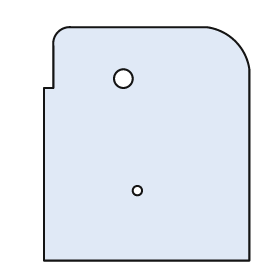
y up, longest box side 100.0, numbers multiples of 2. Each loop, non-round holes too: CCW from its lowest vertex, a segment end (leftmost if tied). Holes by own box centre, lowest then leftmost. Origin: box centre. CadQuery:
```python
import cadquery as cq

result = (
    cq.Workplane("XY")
    .moveTo(-44.0, -50.0)
    .lineTo(44.0, -50.0)
    .lineTo(44.0, 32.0)
    .threePointArc((38.0, 44.0), (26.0, 50.0))
    .lineTo(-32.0, 50.0)
    .threePointArc((-38.0, 48.0), (-40.0, 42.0))
    .lineTo(-40.0, 24.0)
    .lineTo(-44.0, 24.0)
    .close()
    .moveTo(-4.0, -20.0)
    .circle(2.0)
    .moveTo(-10.0, 28.0)
    .circle(4.0)
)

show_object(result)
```